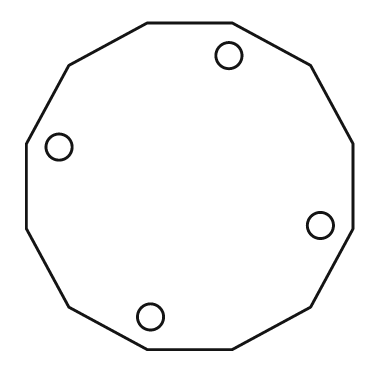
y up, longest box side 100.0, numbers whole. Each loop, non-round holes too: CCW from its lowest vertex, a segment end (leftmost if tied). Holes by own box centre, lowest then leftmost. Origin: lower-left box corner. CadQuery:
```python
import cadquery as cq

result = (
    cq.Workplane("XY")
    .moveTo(37.0, 0.0)
    .lineTo(63.0, 0.0)
    .lineTo(87.0, 13.0)
    .lineTo(100.0, 37.0)
    .lineTo(100.0, 63.0)
    .lineTo(87.0, 87.0)
    .lineTo(63.0, 100.0)
    .lineTo(37.0, 100.0)
    .lineTo(13.0, 87.0)
    .lineTo(0.0, 63.0)
    .lineTo(0.0, 37.0)
    .lineTo(13.0, 13.0)
    .close()
    .moveTo(38.0, 10.0)
    .circle(4.0)
    .moveTo(90.0, 38.0)
    .circle(4.0)
    .moveTo(10.0, 62.0)
    .circle(4.0)
    .moveTo(62.0, 90.0)
    .circle(4.0)
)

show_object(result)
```